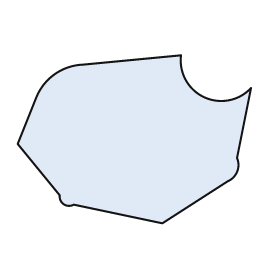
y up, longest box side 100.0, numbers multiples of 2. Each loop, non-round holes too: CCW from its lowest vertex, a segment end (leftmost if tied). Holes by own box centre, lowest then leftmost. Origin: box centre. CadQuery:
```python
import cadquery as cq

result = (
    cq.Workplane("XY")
    .moveTo(12.0, -36.0)
    .lineTo(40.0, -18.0)
    .threePointArc((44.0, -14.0), (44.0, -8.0))
    .lineTo(50.0, 22.0)
    .threePointArc((30.0, 18.0), (20.0, 36.0))
    .lineTo(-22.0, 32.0)
    .threePointArc((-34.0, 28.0), (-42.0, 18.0))
    .lineTo(-50.0, -2.0)
    .lineTo(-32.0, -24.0)
    .threePointArc((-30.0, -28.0), (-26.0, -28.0))
    .close()
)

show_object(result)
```